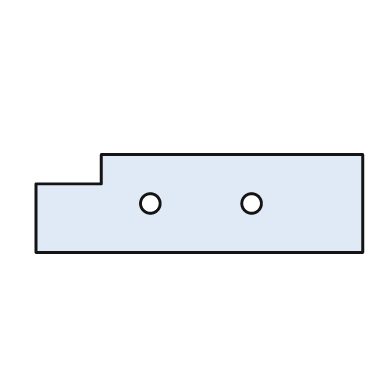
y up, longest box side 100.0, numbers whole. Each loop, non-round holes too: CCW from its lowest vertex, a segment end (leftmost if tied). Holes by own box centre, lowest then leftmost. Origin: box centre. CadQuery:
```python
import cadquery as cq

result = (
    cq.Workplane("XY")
    .moveTo(-50.0, -15.0)
    .lineTo(50.0, -15.0)
    .lineTo(50.0, 15.0)
    .lineTo(-30.0, 15.0)
    .lineTo(-30.0, 6.0)
    .lineTo(-50.0, 6.0)
    .close()
    .moveTo(-15.0, 0.0)
    .circle(3.0)
    .moveTo(16.0, 0.0)
    .circle(3.0)
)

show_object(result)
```